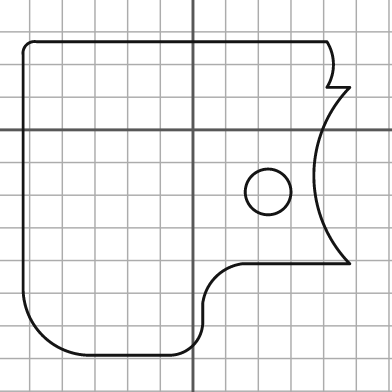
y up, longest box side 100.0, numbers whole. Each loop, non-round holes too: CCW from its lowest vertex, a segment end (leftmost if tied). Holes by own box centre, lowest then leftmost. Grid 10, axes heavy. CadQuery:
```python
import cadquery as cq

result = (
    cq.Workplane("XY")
    .moveTo(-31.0, -69.0)
    .lineTo(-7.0, -69.0)
    .threePointArc((0.0, -66.0), (3.0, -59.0))
    .lineTo(3.0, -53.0)
    .threePointArc((7.0, -45.0), (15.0, -41.0))
    .lineTo(48.0, -41.0)
    .threePointArc((37.0, -14.0), (48.0, 13.0))
    .lineTo(41.0, 13.0)
    .threePointArc((43.0, 20.0), (41.0, 27.0))
    .lineTo(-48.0, 27.0)
    .threePointArc((-51.0, 26.0), (-52.0, 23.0))
    .lineTo(-52.0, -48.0)
    .threePointArc((-46.0, -63.0), (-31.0, -69.0))
    .close()
    .moveTo(23.0, -19.0)
    .circle(7.0)
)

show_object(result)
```